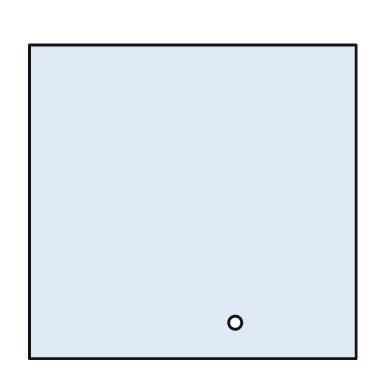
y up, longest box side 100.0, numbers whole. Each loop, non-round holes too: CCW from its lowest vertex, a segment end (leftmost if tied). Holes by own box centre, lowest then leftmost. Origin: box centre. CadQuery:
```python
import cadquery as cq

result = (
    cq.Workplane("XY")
    .moveTo(-50.0, -48.0)
    .lineTo(50.0, -48.0)
    .lineTo(50.0, 48.0)
    .lineTo(-50.0, 48.0)
    .close()
    .moveTo(13.0, -37.0)
    .circle(2.0)
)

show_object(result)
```